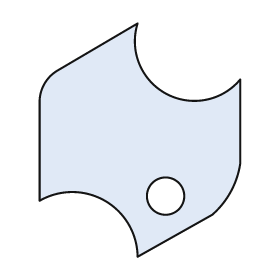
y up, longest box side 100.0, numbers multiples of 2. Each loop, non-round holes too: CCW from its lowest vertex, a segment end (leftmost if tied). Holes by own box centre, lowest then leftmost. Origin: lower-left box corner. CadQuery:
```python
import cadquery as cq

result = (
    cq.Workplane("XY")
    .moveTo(42.0, 0.0)
    .lineTo(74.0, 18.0)
    .threePointArc((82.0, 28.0), (86.0, 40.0))
    .lineTo(86.0, 76.0)
    .threePointArc((54.0, 70.0), (42.0, 100.0))
    .lineTo(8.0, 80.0)
    .threePointArc((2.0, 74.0), (0.0, 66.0))
    .lineTo(0.0, 24.0)
    .threePointArc((28.0, 24.0), (42.0, 0.0))
    .close()
    .moveTo(54.0, 26.0)
    .circle(8.0)
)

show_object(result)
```